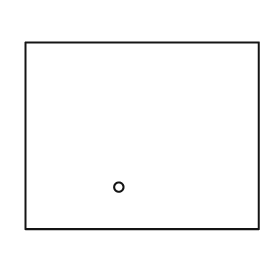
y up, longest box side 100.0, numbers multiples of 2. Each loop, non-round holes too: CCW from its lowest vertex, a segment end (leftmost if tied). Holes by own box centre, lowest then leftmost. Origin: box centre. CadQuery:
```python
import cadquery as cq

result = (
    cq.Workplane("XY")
    .moveTo(-50.0, -40.0)
    .lineTo(50.0, -40.0)
    .lineTo(50.0, 40.0)
    .lineTo(-50.0, 40.0)
    .close()
    .moveTo(-10.0, -22.0)
    .circle(2.0)
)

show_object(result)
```